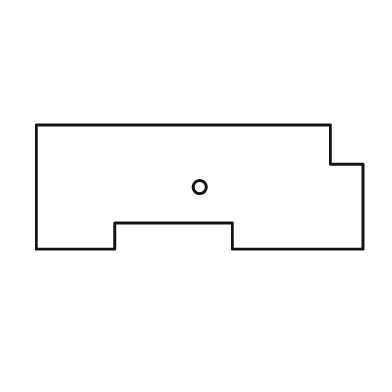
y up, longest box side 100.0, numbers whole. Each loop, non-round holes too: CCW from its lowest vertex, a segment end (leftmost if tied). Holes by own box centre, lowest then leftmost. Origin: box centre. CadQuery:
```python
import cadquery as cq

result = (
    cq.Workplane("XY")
    .moveTo(-50.0, -19.0)
    .lineTo(-26.0, -19.0)
    .lineTo(-26.0, -11.0)
    .lineTo(10.0, -11.0)
    .lineTo(10.0, -19.0)
    .lineTo(50.0, -19.0)
    .lineTo(50.0, 7.0)
    .lineTo(40.0, 7.0)
    .lineTo(40.0, 19.0)
    .lineTo(-50.0, 19.0)
    .close()
    .moveTo(0.0, 0.0)
    .circle(2.0)
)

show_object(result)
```